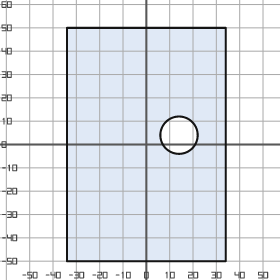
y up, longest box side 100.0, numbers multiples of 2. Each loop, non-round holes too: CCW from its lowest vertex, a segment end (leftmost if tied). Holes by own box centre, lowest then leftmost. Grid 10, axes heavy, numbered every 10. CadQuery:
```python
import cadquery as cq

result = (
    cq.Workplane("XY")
    .moveTo(-34.0, -50.0)
    .lineTo(34.0, -50.0)
    .lineTo(34.0, 50.0)
    .lineTo(-34.0, 50.0)
    .close()
    .moveTo(14.0, 4.0)
    .circle(8.0)
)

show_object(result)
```